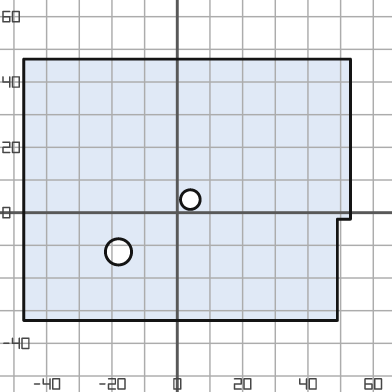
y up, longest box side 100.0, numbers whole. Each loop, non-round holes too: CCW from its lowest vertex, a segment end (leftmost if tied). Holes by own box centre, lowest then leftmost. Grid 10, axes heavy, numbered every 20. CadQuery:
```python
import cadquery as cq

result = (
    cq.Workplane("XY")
    .moveTo(-47.0, -33.0)
    .lineTo(49.0, -33.0)
    .lineTo(49.0, -2.0)
    .lineTo(53.0, -2.0)
    .lineTo(53.0, 47.0)
    .lineTo(-47.0, 47.0)
    .close()
    .moveTo(-18.0, -12.0)
    .circle(4.0)
    .moveTo(4.0, 4.0)
    .circle(3.0)
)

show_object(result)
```